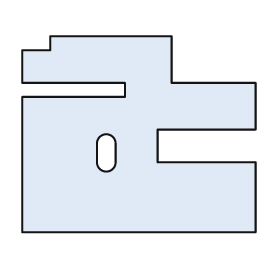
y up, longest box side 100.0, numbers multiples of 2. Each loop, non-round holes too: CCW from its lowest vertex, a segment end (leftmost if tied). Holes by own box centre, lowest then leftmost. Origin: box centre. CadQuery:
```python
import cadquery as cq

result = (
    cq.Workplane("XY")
    .moveTo(-50.0, -42.0)
    .lineTo(50.0, -42.0)
    .lineTo(50.0, -12.0)
    .lineTo(8.0, -12.0)
    .lineTo(8.0, 2.0)
    .lineTo(50.0, 2.0)
    .lineTo(50.0, 22.0)
    .lineTo(14.0, 22.0)
    .lineTo(14.0, 42.0)
    .lineTo(-38.0, 42.0)
    .lineTo(-38.0, 36.0)
    .lineTo(-50.0, 36.0)
    .lineTo(-50.0, 22.0)
    .lineTo(-6.0, 22.0)
    .lineTo(-6.0, 16.0)
    .lineTo(-50.0, 16.0)
    .close()
    .moveTo(-18.0, -12.0)
    .threePointArc((-14.0, -16.0), (-10.0, -12.0))
    .lineTo(-10.0, -4.0)
    .threePointArc((-14.0, 0.0), (-18.0, -4.0))
    .close()
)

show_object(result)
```